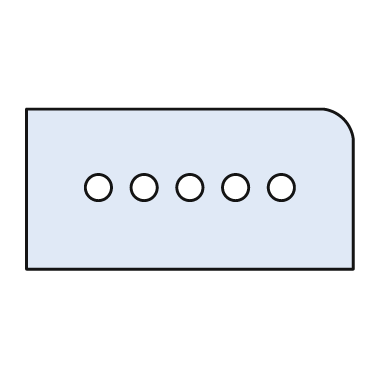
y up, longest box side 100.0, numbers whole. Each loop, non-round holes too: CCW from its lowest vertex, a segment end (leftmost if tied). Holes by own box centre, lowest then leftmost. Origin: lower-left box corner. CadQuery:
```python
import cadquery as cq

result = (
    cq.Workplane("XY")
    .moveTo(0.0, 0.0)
    .lineTo(100.0, 0.0)
    .lineTo(100.0, 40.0)
    .threePointArc((97.0, 46.0), (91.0, 49.0))
    .lineTo(0.0, 49.0)
    .close()
    .moveTo(22.0, 25.0)
    .circle(4.0)
    .moveTo(36.0, 25.0)
    .circle(4.0)
    .moveTo(50.0, 25.0)
    .circle(4.0)
    .moveTo(64.0, 25.0)
    .circle(4.0)
    .moveTo(78.0, 25.0)
    .circle(4.0)
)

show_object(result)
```